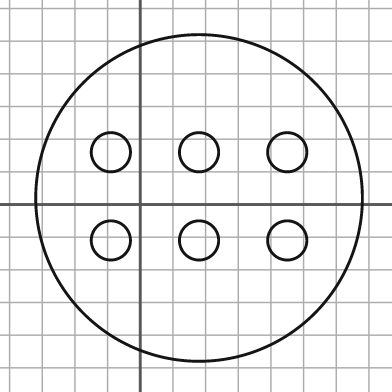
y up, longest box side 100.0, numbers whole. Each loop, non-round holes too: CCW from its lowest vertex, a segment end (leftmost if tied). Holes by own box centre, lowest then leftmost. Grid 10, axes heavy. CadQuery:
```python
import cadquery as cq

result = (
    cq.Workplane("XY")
    .moveTo(18.0, 2.0)
    .circle(50.0)
    .moveTo(-9.0, -11.0)
    .circle(6.0)
    .moveTo(18.0, -11.0)
    .circle(6.0)
    .moveTo(45.0, -11.0)
    .circle(6.0)
    .moveTo(-9.0, 16.0)
    .circle(6.0)
    .moveTo(18.0, 16.0)
    .circle(6.0)
    .moveTo(45.0, 16.0)
    .circle(6.0)
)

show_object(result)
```